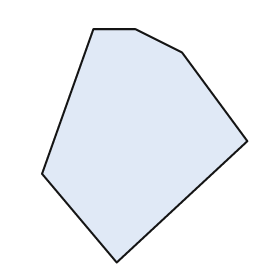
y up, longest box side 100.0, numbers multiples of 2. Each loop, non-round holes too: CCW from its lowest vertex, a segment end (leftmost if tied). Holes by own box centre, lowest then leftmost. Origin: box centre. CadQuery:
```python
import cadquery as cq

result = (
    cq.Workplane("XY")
    .moveTo(-12.0, -50.0)
    .lineTo(44.0, 2.0)
    .lineTo(16.0, 40.0)
    .lineTo(-4.0, 50.0)
    .lineTo(-22.0, 50.0)
    .lineTo(-44.0, -12.0)
    .close()
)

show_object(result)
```